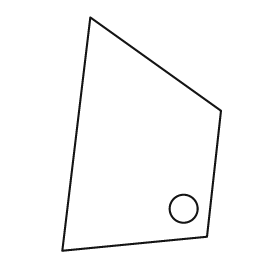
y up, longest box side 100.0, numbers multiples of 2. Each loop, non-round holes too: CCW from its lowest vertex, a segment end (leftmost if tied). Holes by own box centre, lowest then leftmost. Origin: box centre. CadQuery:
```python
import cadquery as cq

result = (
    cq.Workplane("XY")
    .moveTo(-34.0, -50.0)
    .lineTo(28.0, -44.0)
    .lineTo(34.0, 10.0)
    .lineTo(-22.0, 50.0)
    .close()
    .moveTo(18.0, -32.0)
    .circle(6.0)
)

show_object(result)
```